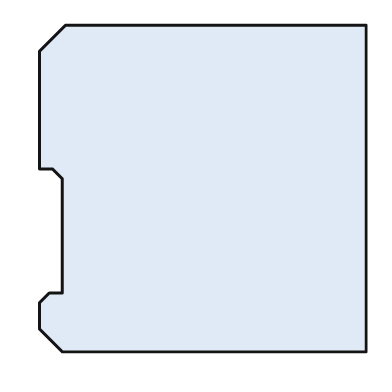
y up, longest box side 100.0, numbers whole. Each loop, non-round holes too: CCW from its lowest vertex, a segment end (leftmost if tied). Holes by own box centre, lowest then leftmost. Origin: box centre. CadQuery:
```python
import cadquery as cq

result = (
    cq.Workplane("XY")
    .moveTo(-43.0, -50.0)
    .lineTo(50.0, -50.0)
    .lineTo(50.0, 50.0)
    .lineTo(-42.0, 50.0)
    .lineTo(-50.0, 42.0)
    .lineTo(-50.0, 6.0)
    .lineTo(-46.0, 6.0)
    .lineTo(-43.0, 3.0)
    .lineTo(-43.0, -32.0)
    .lineTo(-47.0, -32.0)
    .lineTo(-50.0, -35.0)
    .lineTo(-50.0, -43.0)
    .close()
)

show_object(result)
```